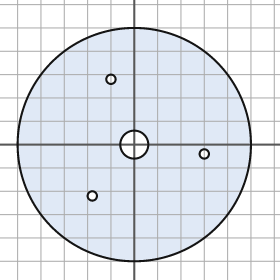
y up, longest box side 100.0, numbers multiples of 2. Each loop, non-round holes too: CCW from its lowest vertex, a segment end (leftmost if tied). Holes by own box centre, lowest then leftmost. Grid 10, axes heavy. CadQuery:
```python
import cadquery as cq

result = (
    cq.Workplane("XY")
    .moveTo(0.0, 0.0)
    .circle(50.0)
    .moveTo(-18.0, -22.0)
    .circle(2.0)
    .moveTo(30.0, -4.0)
    .circle(2.0)
    .moveTo(0.0, 0.0)
    .circle(6.0)
    .moveTo(-10.0, 28.0)
    .circle(2.0)
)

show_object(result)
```